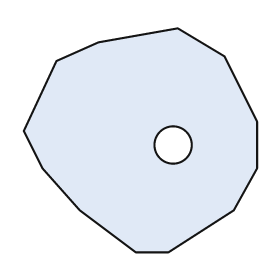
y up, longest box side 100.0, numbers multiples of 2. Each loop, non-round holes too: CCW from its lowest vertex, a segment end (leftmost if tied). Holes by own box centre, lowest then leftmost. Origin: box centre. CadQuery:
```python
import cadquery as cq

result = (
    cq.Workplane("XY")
    .moveTo(-2.0, -48.0)
    .lineTo(12.0, -48.0)
    .lineTo(40.0, -30.0)
    .lineTo(50.0, -12.0)
    .lineTo(50.0, 8.0)
    .lineTo(36.0, 36.0)
    .lineTo(16.0, 48.0)
    .lineTo(-18.0, 42.0)
    .lineTo(-36.0, 34.0)
    .lineTo(-50.0, 4.0)
    .lineTo(-42.0, -12.0)
    .lineTo(-26.0, -30.0)
    .close()
    .moveTo(14.0, -2.0)
    .circle(8.0)
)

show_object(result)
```